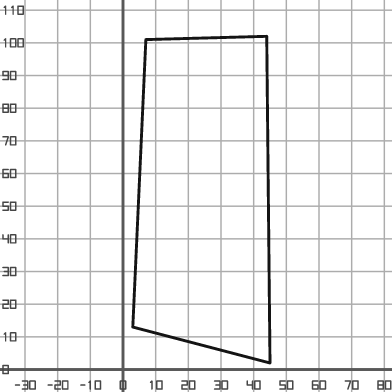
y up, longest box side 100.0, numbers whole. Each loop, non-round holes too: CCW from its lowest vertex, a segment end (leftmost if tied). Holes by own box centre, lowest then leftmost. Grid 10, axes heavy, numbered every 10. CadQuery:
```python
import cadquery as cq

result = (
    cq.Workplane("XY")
    .moveTo(45.0, 2.0)
    .lineTo(44.0, 102.0)
    .lineTo(7.0, 101.0)
    .lineTo(3.0, 13.0)
    .close()
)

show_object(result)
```